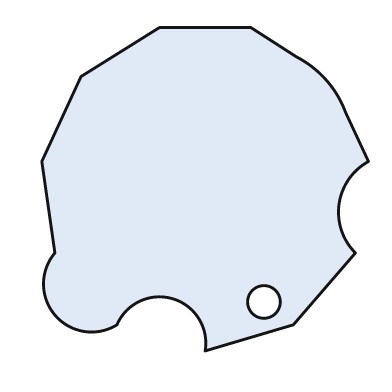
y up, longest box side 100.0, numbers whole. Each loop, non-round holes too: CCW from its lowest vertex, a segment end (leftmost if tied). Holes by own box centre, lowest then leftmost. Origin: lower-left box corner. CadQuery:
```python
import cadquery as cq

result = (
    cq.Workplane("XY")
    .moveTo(50.0, 0.0)
    .lineTo(77.0, 8.0)
    .lineTo(96.0, 30.0)
    .threePointArc((91.0, 45.0), (100.0, 58.0))
    .lineTo(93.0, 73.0)
    .threePointArc((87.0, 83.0), (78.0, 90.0))
    .lineTo(64.0, 99.0)
    .lineTo(36.0, 99.0)
    .lineTo(12.0, 84.0)
    .lineTo(0.0, 58.0)
    .lineTo(4.0, 30.0)
    .threePointArc((4.0, 11.0), (23.0, 8.0))
    .threePointArc((40.0, 16.0), (50.0, 0.0))
    .close()
    .moveTo(68.0, 15.0)
    .circle(5.0)
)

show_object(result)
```